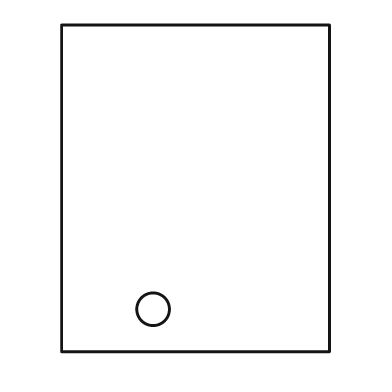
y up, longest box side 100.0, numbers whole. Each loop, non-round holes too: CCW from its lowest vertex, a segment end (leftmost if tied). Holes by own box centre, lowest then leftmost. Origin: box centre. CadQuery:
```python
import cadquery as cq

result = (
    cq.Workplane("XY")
    .moveTo(-41.0, -50.0)
    .lineTo(41.0, -50.0)
    .lineTo(41.0, 50.0)
    .lineTo(-41.0, 50.0)
    .close()
    .moveTo(-13.0, -37.0)
    .circle(5.0)
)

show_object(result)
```